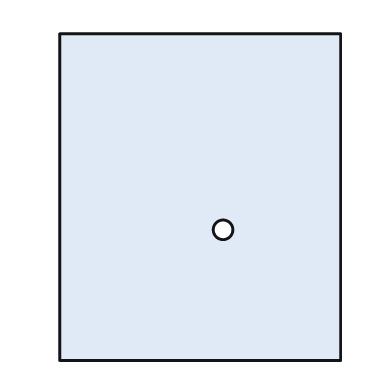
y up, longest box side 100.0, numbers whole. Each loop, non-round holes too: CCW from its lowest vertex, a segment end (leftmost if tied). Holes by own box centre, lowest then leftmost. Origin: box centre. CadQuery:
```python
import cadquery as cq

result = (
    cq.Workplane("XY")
    .moveTo(-43.0, -50.0)
    .lineTo(43.0, -50.0)
    .lineTo(43.0, 50.0)
    .lineTo(-43.0, 50.0)
    .close()
    .moveTo(7.0, -10.0)
    .circle(3.0)
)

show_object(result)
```